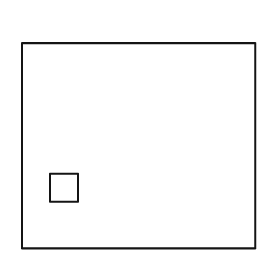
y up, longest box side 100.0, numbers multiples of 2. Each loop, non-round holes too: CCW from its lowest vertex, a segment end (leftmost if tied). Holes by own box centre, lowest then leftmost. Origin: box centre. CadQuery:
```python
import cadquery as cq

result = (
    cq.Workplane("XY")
    .moveTo(-50.0, -44.0)
    .lineTo(50.0, -44.0)
    .lineTo(50.0, 44.0)
    .lineTo(-50.0, 44.0)
    .close()
    .moveTo(-38.0, -24.0)
    .lineTo(-26.0, -24.0)
    .lineTo(-26.0, -12.0)
    .lineTo(-38.0, -12.0)
    .close()
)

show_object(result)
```